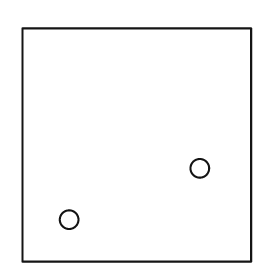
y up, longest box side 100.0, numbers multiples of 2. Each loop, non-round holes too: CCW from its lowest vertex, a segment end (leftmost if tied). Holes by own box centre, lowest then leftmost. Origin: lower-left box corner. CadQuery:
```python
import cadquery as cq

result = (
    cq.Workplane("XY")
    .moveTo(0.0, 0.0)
    .lineTo(98.0, 0.0)
    .lineTo(98.0, 100.0)
    .lineTo(0.0, 100.0)
    .close()
    .moveTo(20.0, 18.0)
    .circle(4.0)
    .moveTo(76.0, 40.0)
    .circle(4.0)
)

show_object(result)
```